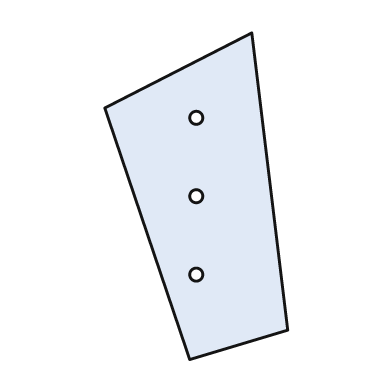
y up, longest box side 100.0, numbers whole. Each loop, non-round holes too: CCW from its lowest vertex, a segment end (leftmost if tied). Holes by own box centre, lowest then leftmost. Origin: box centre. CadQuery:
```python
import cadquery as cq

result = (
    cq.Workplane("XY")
    .moveTo(-2.0, -50.0)
    .lineTo(28.0, -41.0)
    .lineTo(17.0, 50.0)
    .lineTo(-28.0, 27.0)
    .close()
    .moveTo(0.0, -24.0)
    .circle(2.0)
    .moveTo(0.0, 0.0)
    .circle(2.0)
    .moveTo(0.0, 24.0)
    .circle(2.0)
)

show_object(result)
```